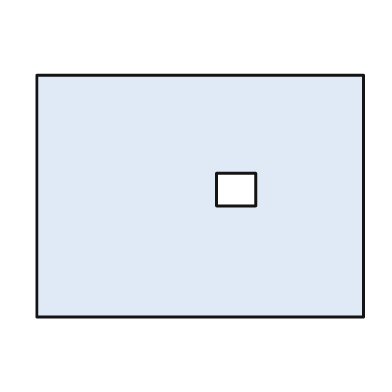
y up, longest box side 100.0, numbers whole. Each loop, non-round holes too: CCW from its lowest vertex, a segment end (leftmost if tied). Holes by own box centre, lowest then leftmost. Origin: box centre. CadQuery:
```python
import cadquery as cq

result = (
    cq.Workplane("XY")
    .moveTo(-50.0, -37.0)
    .lineTo(50.0, -37.0)
    .lineTo(50.0, 37.0)
    .lineTo(-50.0, 37.0)
    .close()
    .moveTo(5.0, -3.0)
    .lineTo(17.0, -3.0)
    .lineTo(17.0, 7.0)
    .lineTo(5.0, 7.0)
    .close()
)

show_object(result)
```